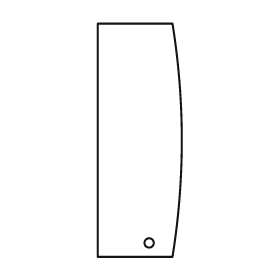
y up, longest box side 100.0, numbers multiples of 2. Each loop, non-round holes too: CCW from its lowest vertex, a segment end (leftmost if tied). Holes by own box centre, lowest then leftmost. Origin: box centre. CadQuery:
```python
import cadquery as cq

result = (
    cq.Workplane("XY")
    .moveTo(-18.0, -50.0)
    .lineTo(14.0, -50.0)
    .threePointArc((18.0, 0.0), (14.0, 50.0))
    .lineTo(-18.0, 50.0)
    .close()
    .moveTo(4.0, -44.0)
    .circle(2.0)
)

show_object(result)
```